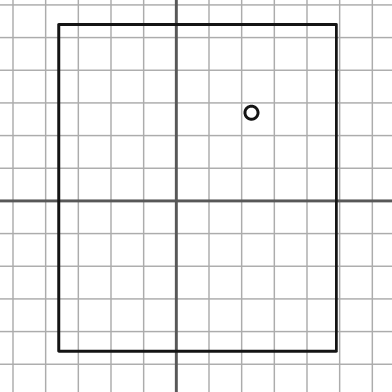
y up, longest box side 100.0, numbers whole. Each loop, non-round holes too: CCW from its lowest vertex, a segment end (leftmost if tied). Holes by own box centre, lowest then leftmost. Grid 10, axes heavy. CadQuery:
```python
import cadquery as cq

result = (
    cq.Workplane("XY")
    .moveTo(-36.0, -46.0)
    .lineTo(49.0, -46.0)
    .lineTo(49.0, 54.0)
    .lineTo(-36.0, 54.0)
    .close()
    .moveTo(23.0, 27.0)
    .circle(2.0)
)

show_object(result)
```